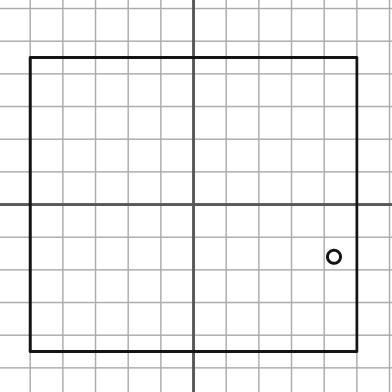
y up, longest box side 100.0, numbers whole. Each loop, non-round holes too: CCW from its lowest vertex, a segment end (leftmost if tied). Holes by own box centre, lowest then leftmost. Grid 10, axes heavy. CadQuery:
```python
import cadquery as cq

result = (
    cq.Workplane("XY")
    .moveTo(-50.0, -45.0)
    .lineTo(50.0, -45.0)
    .lineTo(50.0, 45.0)
    .lineTo(-50.0, 45.0)
    .close()
    .moveTo(43.0, -16.0)
    .circle(2.0)
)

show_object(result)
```